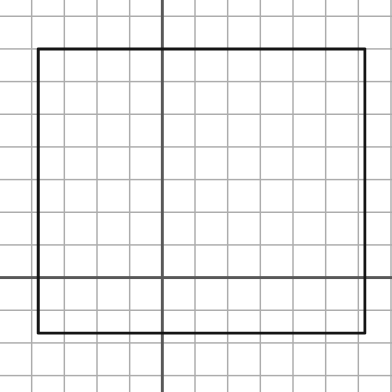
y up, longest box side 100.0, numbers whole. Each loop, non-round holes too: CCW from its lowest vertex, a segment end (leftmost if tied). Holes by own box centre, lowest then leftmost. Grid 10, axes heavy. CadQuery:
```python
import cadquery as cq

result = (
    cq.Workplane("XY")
    .moveTo(-38.0, -17.0)
    .lineTo(62.0, -17.0)
    .lineTo(62.0, 70.0)
    .lineTo(-38.0, 70.0)
    .close()
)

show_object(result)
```